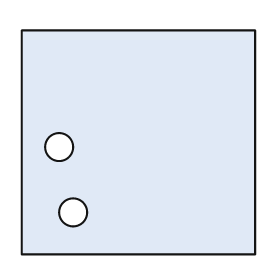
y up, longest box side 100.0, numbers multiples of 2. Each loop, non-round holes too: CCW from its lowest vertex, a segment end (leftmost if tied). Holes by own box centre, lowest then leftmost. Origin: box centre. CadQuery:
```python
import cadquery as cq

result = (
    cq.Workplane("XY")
    .moveTo(-50.0, -48.0)
    .lineTo(50.0, -48.0)
    .lineTo(50.0, 48.0)
    .lineTo(-50.0, 48.0)
    .close()
    .moveTo(-28.0, -30.0)
    .circle(6.0)
    .moveTo(-34.0, -2.0)
    .circle(6.0)
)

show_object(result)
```